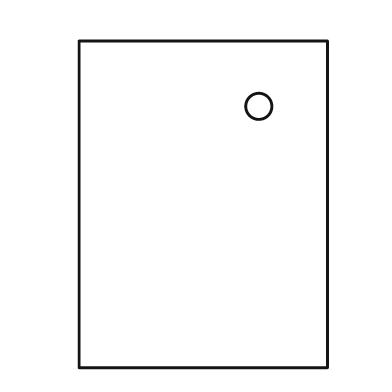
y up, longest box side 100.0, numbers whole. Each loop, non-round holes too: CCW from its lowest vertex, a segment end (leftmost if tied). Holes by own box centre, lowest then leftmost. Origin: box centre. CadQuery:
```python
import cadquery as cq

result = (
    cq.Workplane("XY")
    .moveTo(-38.0, -50.0)
    .lineTo(38.0, -50.0)
    .lineTo(38.0, 50.0)
    .lineTo(-38.0, 50.0)
    .close()
    .moveTo(17.0, 30.0)
    .circle(4.0)
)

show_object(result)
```